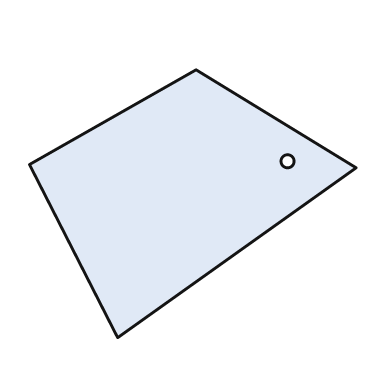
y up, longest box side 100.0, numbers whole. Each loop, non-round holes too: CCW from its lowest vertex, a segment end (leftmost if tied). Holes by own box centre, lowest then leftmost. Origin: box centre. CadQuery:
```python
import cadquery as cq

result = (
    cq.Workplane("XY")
    .moveTo(-23.0, -41.0)
    .lineTo(50.0, 11.0)
    .lineTo(1.0, 41.0)
    .lineTo(-50.0, 12.0)
    .close()
    .moveTo(29.0, 13.0)
    .circle(2.0)
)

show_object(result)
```